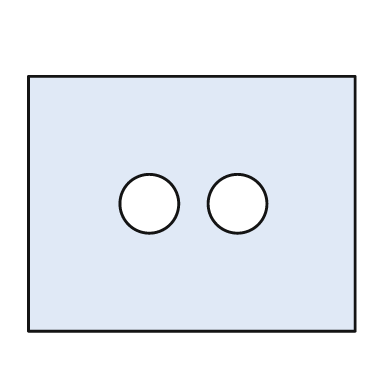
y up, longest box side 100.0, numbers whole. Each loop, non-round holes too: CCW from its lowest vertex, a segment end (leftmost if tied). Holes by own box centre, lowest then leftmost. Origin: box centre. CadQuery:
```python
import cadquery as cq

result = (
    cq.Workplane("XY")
    .moveTo(-50.0, -39.0)
    .lineTo(50.0, -39.0)
    .lineTo(50.0, 39.0)
    .lineTo(-50.0, 39.0)
    .close()
    .moveTo(-13.0, 0.0)
    .circle(9.0)
    .moveTo(14.0, 0.0)
    .circle(9.0)
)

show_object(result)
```